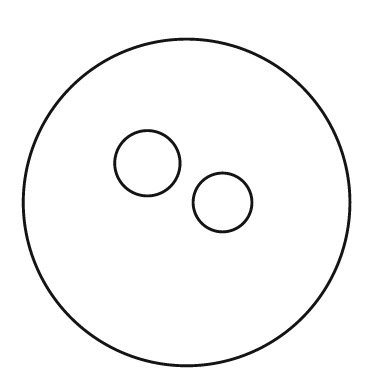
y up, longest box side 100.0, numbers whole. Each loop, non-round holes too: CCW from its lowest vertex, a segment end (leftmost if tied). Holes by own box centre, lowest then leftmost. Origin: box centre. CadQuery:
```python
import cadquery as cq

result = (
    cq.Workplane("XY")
    .moveTo(0.0, 0.0)
    .circle(50.0)
    .moveTo(11.0, 0.0)
    .circle(9.0)
    .moveTo(-12.0, 12.0)
    .circle(10.0)
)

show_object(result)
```